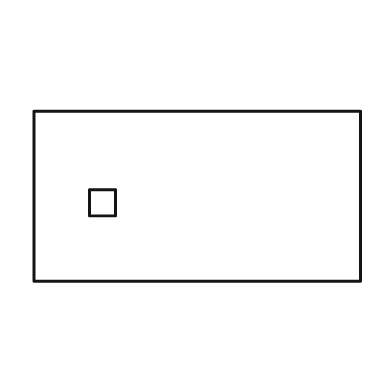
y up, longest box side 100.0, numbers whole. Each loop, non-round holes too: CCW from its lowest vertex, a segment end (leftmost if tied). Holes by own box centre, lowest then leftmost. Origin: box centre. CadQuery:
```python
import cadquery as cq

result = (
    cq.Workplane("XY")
    .moveTo(-50.0, -26.0)
    .lineTo(50.0, -26.0)
    .lineTo(50.0, 26.0)
    .lineTo(-50.0, 26.0)
    .close()
    .moveTo(-33.0, -6.0)
    .lineTo(-25.0, -6.0)
    .lineTo(-25.0, 2.0)
    .lineTo(-33.0, 2.0)
    .close()
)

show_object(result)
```